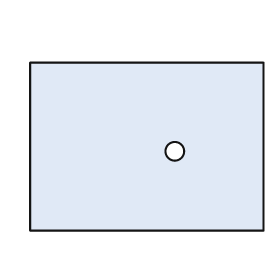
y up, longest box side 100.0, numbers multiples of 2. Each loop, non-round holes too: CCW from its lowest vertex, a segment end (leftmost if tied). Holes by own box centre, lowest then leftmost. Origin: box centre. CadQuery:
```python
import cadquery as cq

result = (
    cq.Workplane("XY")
    .moveTo(-50.0, -36.0)
    .lineTo(50.0, -36.0)
    .lineTo(50.0, 36.0)
    .lineTo(-50.0, 36.0)
    .close()
    .moveTo(12.0, -2.0)
    .circle(4.0)
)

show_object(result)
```